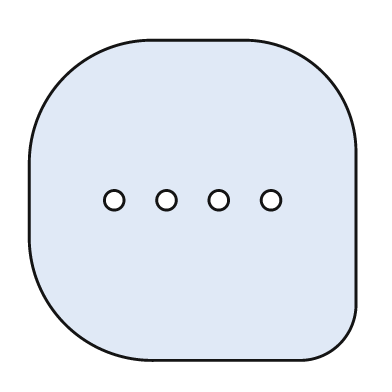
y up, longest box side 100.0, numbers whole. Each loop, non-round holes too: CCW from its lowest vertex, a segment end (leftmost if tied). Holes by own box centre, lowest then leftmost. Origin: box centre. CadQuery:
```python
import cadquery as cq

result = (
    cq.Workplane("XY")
    .moveTo(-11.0, -49.0)
    .lineTo(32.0, -49.0)
    .threePointArc((45.0, -44.0), (50.0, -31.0))
    .lineTo(50.0, 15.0)
    .threePointArc((40.0, 39.0), (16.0, 49.0))
    .lineTo(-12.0, 49.0)
    .threePointArc((-39.0, 38.0), (-50.0, 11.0))
    .lineTo(-50.0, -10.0)
    .threePointArc((-39.0, -38.0), (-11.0, -49.0))
    .close()
    .moveTo(-24.0, 0.0)
    .circle(3.0)
    .moveTo(-8.0, 0.0)
    .circle(3.0)
    .moveTo(8.0, 0.0)
    .circle(3.0)
    .moveTo(24.0, 0.0)
    .circle(3.0)
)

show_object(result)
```